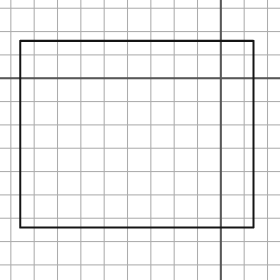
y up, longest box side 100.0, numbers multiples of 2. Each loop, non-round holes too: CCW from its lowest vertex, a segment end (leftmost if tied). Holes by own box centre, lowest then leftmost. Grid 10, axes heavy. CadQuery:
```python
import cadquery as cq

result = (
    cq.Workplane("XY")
    .moveTo(-86.0, -64.0)
    .lineTo(14.0, -64.0)
    .lineTo(14.0, 16.0)
    .lineTo(-86.0, 16.0)
    .close()
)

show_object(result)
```